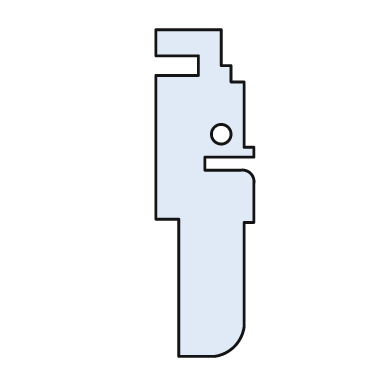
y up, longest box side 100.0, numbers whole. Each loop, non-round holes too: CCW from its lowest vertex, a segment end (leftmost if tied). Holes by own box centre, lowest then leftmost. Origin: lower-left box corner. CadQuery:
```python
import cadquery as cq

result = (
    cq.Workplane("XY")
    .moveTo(7.0, 0.0)
    .lineTo(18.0, 0.0)
    .threePointArc((24.0, 3.0), (27.0, 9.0))
    .lineTo(27.0, 41.0)
    .lineTo(30.0, 41.0)
    .lineTo(30.0, 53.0)
    .threePointArc((29.0, 56.0), (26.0, 57.0))
    .lineTo(15.0, 57.0)
    .lineTo(15.0, 61.0)
    .lineTo(30.0, 61.0)
    .lineTo(30.0, 64.0)
    .lineTo(27.0, 64.0)
    .lineTo(27.0, 84.0)
    .lineTo(23.0, 84.0)
    .lineTo(23.0, 89.0)
    .lineTo(20.0, 89.0)
    .lineTo(20.0, 100.0)
    .lineTo(0.0, 100.0)
    .lineTo(0.0, 92.0)
    .lineTo(13.0, 92.0)
    .lineTo(13.0, 86.0)
    .lineTo(0.0, 86.0)
    .lineTo(0.0, 42.0)
    .lineTo(7.0, 42.0)
    .close()
    .moveTo(20.0, 68.0)
    .circle(3.0)
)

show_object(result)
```